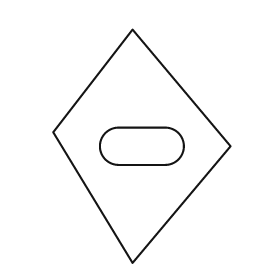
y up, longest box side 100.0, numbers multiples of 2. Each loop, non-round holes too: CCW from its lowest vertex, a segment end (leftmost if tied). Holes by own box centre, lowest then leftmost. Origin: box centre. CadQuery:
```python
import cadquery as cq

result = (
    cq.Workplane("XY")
    .moveTo(-4.0, -50.0)
    .lineTo(38.0, 0.0)
    .lineTo(-4.0, 50.0)
    .lineTo(-38.0, 6.0)
    .close()
    .moveTo(-10.0, -8.0)
    .lineTo(10.0, -8.0)
    .threePointArc((18.0, 0.0), (10.0, 8.0))
    .lineTo(-10.0, 8.0)
    .threePointArc((-18.0, 0.0), (-10.0, -8.0))
    .close()
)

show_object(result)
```